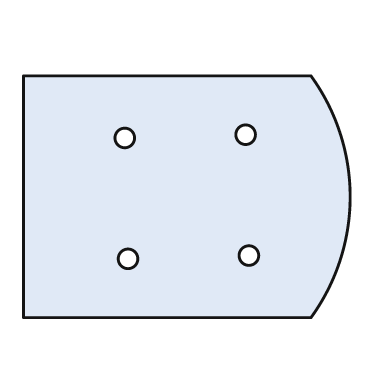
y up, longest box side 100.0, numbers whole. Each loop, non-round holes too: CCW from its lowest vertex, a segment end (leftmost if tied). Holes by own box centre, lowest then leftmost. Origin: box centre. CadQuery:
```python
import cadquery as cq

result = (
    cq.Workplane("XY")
    .moveTo(-50.0, -37.0)
    .lineTo(38.0, -37.0)
    .threePointArc((50.0, 0.0), (38.0, 37.0))
    .lineTo(-50.0, 37.0)
    .close()
    .moveTo(-18.0, -19.0)
    .circle(3.0)
    .moveTo(19.0, -18.0)
    .circle(3.0)
    .moveTo(-19.0, 18.0)
    .circle(3.0)
    .moveTo(18.0, 19.0)
    .circle(3.0)
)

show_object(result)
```